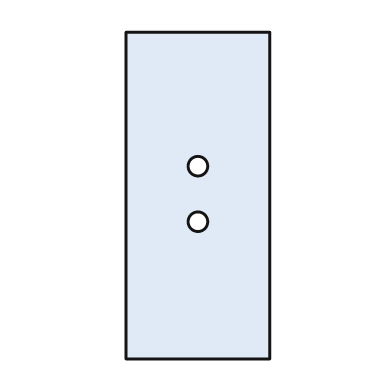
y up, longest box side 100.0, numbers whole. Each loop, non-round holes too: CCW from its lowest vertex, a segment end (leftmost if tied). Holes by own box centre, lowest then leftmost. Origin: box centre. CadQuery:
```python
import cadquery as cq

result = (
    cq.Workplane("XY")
    .moveTo(-22.0, -50.0)
    .lineTo(22.0, -50.0)
    .lineTo(22.0, 50.0)
    .lineTo(-22.0, 50.0)
    .close()
    .moveTo(0.0, -8.0)
    .circle(3.0)
    .moveTo(0.0, 9.0)
    .circle(3.0)
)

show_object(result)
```